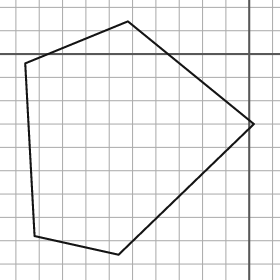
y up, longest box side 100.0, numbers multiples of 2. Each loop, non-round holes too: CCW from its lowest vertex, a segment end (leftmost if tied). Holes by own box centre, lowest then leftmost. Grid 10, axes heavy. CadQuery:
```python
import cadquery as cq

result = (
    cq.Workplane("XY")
    .moveTo(-56.0, -86.0)
    .lineTo(2.0, -30.0)
    .lineTo(-52.0, 14.0)
    .lineTo(-96.0, -4.0)
    .lineTo(-92.0, -78.0)
    .close()
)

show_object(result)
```